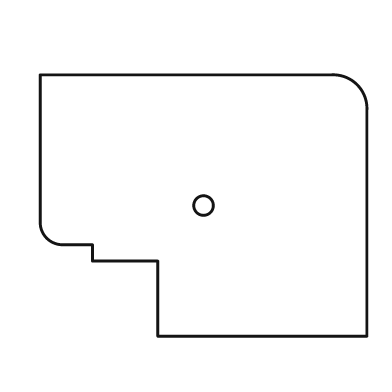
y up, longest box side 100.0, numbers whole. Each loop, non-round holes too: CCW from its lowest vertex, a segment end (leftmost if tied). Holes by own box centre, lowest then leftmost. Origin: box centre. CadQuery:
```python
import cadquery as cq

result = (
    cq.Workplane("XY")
    .moveTo(-14.0, -40.0)
    .lineTo(50.0, -40.0)
    .lineTo(50.0, 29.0)
    .threePointArc((47.0, 37.0), (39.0, 40.0))
    .lineTo(-50.0, 40.0)
    .lineTo(-50.0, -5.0)
    .threePointArc((-48.0, -10.0), (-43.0, -12.0))
    .lineTo(-34.0, -12.0)
    .lineTo(-34.0, -17.0)
    .lineTo(-14.0, -17.0)
    .close()
    .moveTo(0.0, 0.0)
    .circle(3.0)
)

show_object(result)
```